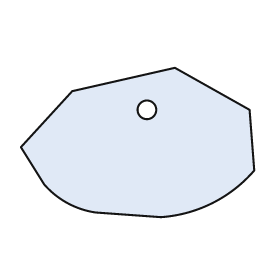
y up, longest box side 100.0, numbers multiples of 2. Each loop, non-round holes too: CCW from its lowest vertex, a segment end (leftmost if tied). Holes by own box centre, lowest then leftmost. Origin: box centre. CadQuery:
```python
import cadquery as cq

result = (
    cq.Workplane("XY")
    .moveTo(10.0, -32.0)
    .threePointArc((32.0, -26.0), (50.0, -12.0))
    .lineTo(48.0, 14.0)
    .lineTo(16.0, 32.0)
    .lineTo(-28.0, 22.0)
    .lineTo(-50.0, -2.0)
    .lineTo(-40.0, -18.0)
    .threePointArc((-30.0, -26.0), (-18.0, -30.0))
    .close()
    .moveTo(4.0, 14.0)
    .circle(4.0)
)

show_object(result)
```